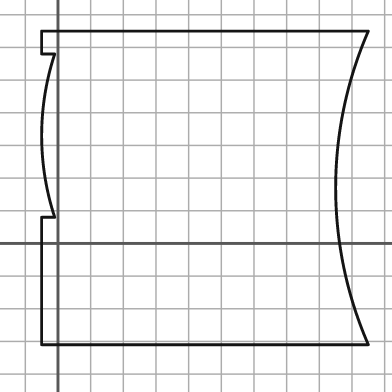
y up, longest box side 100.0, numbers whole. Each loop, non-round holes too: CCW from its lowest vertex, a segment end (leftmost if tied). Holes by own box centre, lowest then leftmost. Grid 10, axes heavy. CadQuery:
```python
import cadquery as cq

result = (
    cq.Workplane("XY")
    .moveTo(-5.0, -31.0)
    .lineTo(95.0, -31.0)
    .threePointArc((85.0, 17.0), (95.0, 65.0))
    .lineTo(-5.0, 65.0)
    .lineTo(-5.0, 58.0)
    .lineTo(-1.0, 58.0)
    .threePointArc((-5.0, 33.0), (-1.0, 8.0))
    .lineTo(-5.0, 8.0)
    .close()
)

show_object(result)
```